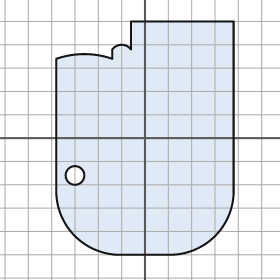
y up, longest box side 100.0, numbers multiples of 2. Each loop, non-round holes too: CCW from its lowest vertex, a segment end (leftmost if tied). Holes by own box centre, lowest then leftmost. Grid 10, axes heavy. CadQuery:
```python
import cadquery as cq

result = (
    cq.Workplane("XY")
    .moveTo(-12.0, -50.0)
    .lineTo(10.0, -50.0)
    .threePointArc((30.0, -42.0), (38.0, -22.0))
    .lineTo(38.0, 50.0)
    .lineTo(-6.0, 50.0)
    .lineTo(-6.0, 38.0)
    .threePointArc((-10.0, 40.0), (-14.0, 38.0))
    .lineTo(-14.0, 34.0)
    .threePointArc((-26.0, 36.0), (-38.0, 34.0))
    .lineTo(-38.0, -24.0)
    .threePointArc((-30.0, -42.0), (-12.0, -50.0))
    .close()
    .moveTo(-30.0, -16.0)
    .circle(4.0)
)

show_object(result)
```